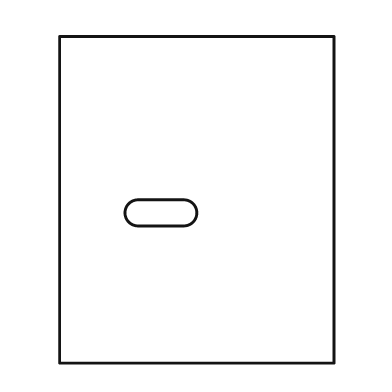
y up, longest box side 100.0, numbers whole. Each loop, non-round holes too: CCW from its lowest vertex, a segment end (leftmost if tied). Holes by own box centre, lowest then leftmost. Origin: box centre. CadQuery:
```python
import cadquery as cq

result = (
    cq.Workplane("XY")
    .moveTo(-42.0, -50.0)
    .lineTo(42.0, -50.0)
    .lineTo(42.0, 50.0)
    .lineTo(-42.0, 50.0)
    .close()
    .moveTo(-18.0, -8.0)
    .lineTo(-4.0, -8.0)
    .threePointArc((0.0, -4.0), (-4.0, 0.0))
    .lineTo(-18.0, 0.0)
    .threePointArc((-22.0, -4.0), (-18.0, -8.0))
    .close()
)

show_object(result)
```